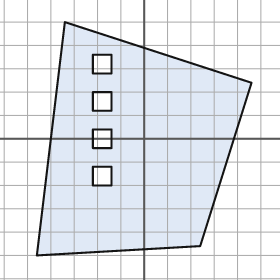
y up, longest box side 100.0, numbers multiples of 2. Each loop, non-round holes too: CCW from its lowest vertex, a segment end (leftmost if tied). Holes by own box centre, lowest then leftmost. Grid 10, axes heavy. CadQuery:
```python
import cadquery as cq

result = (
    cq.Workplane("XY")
    .moveTo(-46.0, -50.0)
    .lineTo(24.0, -46.0)
    .lineTo(46.0, 24.0)
    .lineTo(-34.0, 50.0)
    .close()
    .moveTo(-22.0, -20.0)
    .lineTo(-14.0, -20.0)
    .lineTo(-14.0, -12.0)
    .lineTo(-22.0, -12.0)
    .close()
    .moveTo(-22.0, -4.0)
    .lineTo(-14.0, -4.0)
    .lineTo(-14.0, 4.0)
    .lineTo(-22.0, 4.0)
    .close()
    .moveTo(-22.0, 12.0)
    .lineTo(-14.0, 12.0)
    .lineTo(-14.0, 20.0)
    .lineTo(-22.0, 20.0)
    .close()
    .moveTo(-22.0, 28.0)
    .lineTo(-14.0, 28.0)
    .lineTo(-14.0, 36.0)
    .lineTo(-22.0, 36.0)
    .close()
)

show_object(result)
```